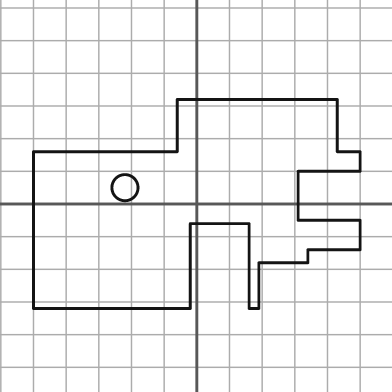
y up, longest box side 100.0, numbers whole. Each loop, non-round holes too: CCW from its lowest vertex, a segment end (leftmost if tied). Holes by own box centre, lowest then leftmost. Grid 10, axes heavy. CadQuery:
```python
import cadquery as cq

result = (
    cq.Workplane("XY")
    .moveTo(-50.0, -32.0)
    .lineTo(-2.0, -32.0)
    .lineTo(-2.0, -6.0)
    .lineTo(16.0, -6.0)
    .lineTo(16.0, -32.0)
    .lineTo(19.0, -32.0)
    .lineTo(19.0, -18.0)
    .lineTo(34.0, -18.0)
    .lineTo(34.0, -14.0)
    .lineTo(50.0, -14.0)
    .lineTo(50.0, -5.0)
    .lineTo(31.0, -5.0)
    .lineTo(31.0, 10.0)
    .lineTo(50.0, 10.0)
    .lineTo(50.0, 16.0)
    .lineTo(43.0, 16.0)
    .lineTo(43.0, 32.0)
    .lineTo(-6.0, 32.0)
    .lineTo(-6.0, 16.0)
    .lineTo(-50.0, 16.0)
    .close()
    .moveTo(-22.0, 5.0)
    .circle(4.0)
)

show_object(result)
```